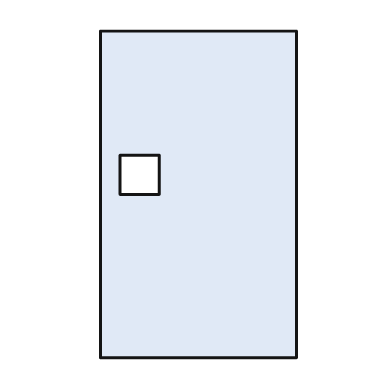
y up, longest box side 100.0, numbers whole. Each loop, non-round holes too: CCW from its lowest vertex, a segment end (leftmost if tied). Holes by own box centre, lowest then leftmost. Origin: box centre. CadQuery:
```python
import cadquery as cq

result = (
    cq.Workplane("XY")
    .moveTo(-30.0, -50.0)
    .lineTo(30.0, -50.0)
    .lineTo(30.0, 50.0)
    .lineTo(-30.0, 50.0)
    .close()
    .moveTo(-24.0, 0.0)
    .lineTo(-12.0, 0.0)
    .lineTo(-12.0, 12.0)
    .lineTo(-24.0, 12.0)
    .close()
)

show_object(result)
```